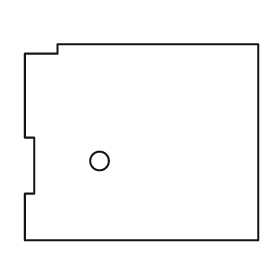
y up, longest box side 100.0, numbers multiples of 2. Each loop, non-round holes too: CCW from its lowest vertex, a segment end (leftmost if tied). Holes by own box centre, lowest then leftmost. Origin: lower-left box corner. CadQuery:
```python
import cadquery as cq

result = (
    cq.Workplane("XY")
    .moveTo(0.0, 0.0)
    .lineTo(100.0, 0.0)
    .lineTo(100.0, 84.0)
    .lineTo(14.0, 84.0)
    .lineTo(14.0, 80.0)
    .lineTo(0.0, 80.0)
    .lineTo(0.0, 44.0)
    .lineTo(4.0, 44.0)
    .lineTo(4.0, 20.0)
    .lineTo(0.0, 20.0)
    .close()
    .moveTo(32.0, 34.0)
    .circle(4.0)
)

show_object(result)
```